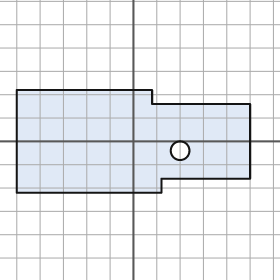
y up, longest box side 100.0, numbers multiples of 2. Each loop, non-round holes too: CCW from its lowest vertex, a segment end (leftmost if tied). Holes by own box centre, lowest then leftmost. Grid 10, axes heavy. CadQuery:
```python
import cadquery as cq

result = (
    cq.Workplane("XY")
    .moveTo(-50.0, -22.0)
    .lineTo(12.0, -22.0)
    .lineTo(12.0, -16.0)
    .lineTo(50.0, -16.0)
    .lineTo(50.0, 16.0)
    .lineTo(8.0, 16.0)
    .lineTo(8.0, 22.0)
    .lineTo(-50.0, 22.0)
    .close()
    .moveTo(20.0, -4.0)
    .circle(4.0)
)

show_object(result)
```